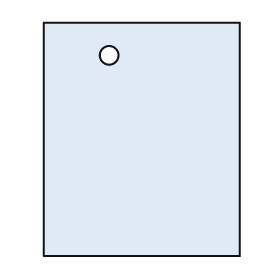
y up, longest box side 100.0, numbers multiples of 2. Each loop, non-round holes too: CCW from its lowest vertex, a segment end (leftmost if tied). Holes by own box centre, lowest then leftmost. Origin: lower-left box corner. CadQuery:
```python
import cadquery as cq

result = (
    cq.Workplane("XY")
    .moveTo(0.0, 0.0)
    .lineTo(84.0, 0.0)
    .lineTo(84.0, 100.0)
    .lineTo(0.0, 100.0)
    .close()
    .moveTo(28.0, 86.0)
    .circle(4.0)
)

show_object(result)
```